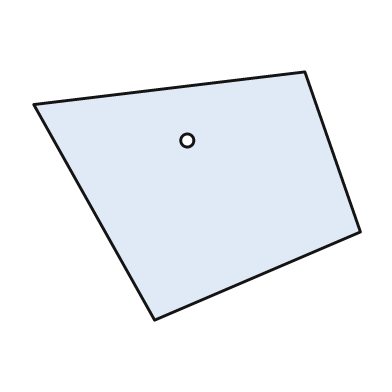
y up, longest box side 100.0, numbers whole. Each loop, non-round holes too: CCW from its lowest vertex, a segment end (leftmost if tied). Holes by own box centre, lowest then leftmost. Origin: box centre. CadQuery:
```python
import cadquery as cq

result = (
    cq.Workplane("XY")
    .moveTo(-13.0, -38.0)
    .lineTo(50.0, -11.0)
    .lineTo(33.0, 38.0)
    .lineTo(-50.0, 28.0)
    .close()
    .moveTo(-3.0, 17.0)
    .circle(2.0)
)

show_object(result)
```